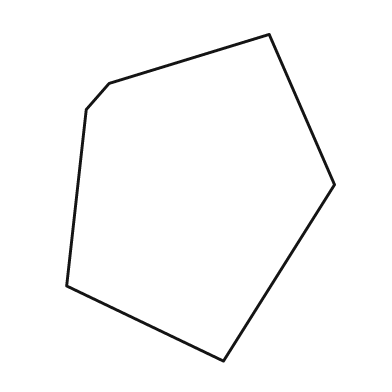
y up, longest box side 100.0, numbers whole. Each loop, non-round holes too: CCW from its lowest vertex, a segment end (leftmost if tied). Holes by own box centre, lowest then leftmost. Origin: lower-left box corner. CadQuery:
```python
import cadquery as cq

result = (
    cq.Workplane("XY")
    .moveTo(48.0, 0.0)
    .lineTo(82.0, 54.0)
    .lineTo(62.0, 100.0)
    .lineTo(13.0, 85.0)
    .lineTo(6.0, 77.0)
    .lineTo(0.0, 23.0)
    .close()
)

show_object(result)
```